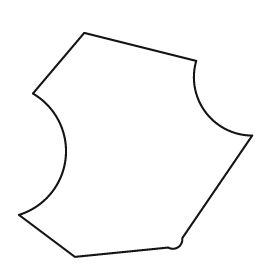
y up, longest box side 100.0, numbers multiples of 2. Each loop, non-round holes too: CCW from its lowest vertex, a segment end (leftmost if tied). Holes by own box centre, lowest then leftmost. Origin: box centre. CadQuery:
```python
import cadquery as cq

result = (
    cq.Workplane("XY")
    .moveTo(-26.0, -48.0)
    .lineTo(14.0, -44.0)
    .threePointArc((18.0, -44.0), (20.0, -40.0))
    .lineTo(50.0, 4.0)
    .threePointArc((30.0, 14.0), (26.0, 36.0))
    .lineTo(-22.0, 48.0)
    .lineTo(-44.0, 22.0)
    .threePointArc((-30.0, -6.0), (-50.0, -30.0))
    .close()
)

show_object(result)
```